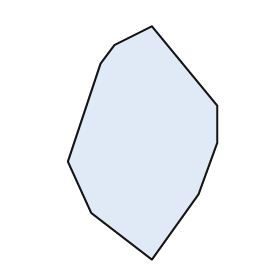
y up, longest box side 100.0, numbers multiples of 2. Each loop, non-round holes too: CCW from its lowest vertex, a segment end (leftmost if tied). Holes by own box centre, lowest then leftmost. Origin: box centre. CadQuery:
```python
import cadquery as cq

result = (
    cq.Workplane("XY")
    .moveTo(4.0, -50.0)
    .lineTo(24.0, -22.0)
    .lineTo(32.0, 0.0)
    .lineTo(32.0, 16.0)
    .lineTo(4.0, 50.0)
    .lineTo(-12.0, 42.0)
    .lineTo(-18.0, 34.0)
    .lineTo(-32.0, -8.0)
    .lineTo(-22.0, -30.0)
    .close()
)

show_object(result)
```